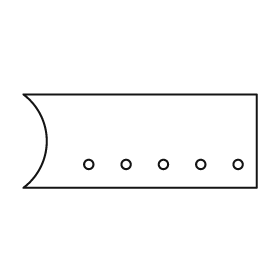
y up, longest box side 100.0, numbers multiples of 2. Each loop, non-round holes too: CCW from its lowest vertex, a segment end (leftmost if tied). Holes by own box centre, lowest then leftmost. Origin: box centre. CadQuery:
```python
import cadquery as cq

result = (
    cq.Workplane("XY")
    .moveTo(-50.0, -20.0)
    .lineTo(50.0, -20.0)
    .lineTo(50.0, 20.0)
    .lineTo(-50.0, 20.0)
    .threePointArc((-40.0, 0.0), (-50.0, -20.0))
    .close()
    .moveTo(-22.0, -10.0)
    .circle(2.0)
    .moveTo(-6.0, -10.0)
    .circle(2.0)
    .moveTo(10.0, -10.0)
    .circle(2.0)
    .moveTo(26.0, -10.0)
    .circle(2.0)
    .moveTo(42.0, -10.0)
    .circle(2.0)
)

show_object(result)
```